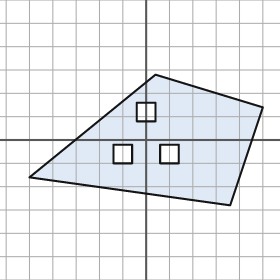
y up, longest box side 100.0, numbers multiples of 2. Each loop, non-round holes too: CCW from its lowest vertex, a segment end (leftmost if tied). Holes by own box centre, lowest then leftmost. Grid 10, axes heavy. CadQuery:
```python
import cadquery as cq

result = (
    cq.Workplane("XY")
    .moveTo(36.0, -28.0)
    .lineTo(50.0, 14.0)
    .lineTo(4.0, 28.0)
    .lineTo(-50.0, -16.0)
    .close()
    .moveTo(-14.0, -10.0)
    .lineTo(-6.0, -10.0)
    .lineTo(-6.0, -2.0)
    .lineTo(-14.0, -2.0)
    .close()
    .moveTo(6.0, -10.0)
    .lineTo(14.0, -10.0)
    .lineTo(14.0, -2.0)
    .lineTo(6.0, -2.0)
    .close()
    .moveTo(-4.0, 8.0)
    .lineTo(4.0, 8.0)
    .lineTo(4.0, 16.0)
    .lineTo(-4.0, 16.0)
    .close()
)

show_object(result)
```